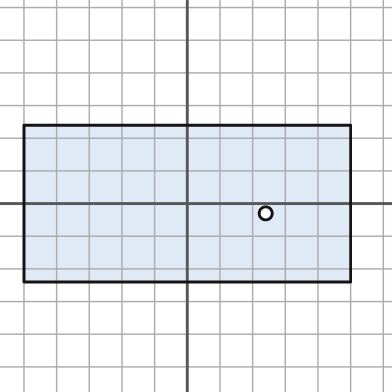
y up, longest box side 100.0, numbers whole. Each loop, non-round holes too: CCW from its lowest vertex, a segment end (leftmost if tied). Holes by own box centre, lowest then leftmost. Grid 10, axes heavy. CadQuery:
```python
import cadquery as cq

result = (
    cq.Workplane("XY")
    .moveTo(-50.0, -24.0)
    .lineTo(50.0, -24.0)
    .lineTo(50.0, 24.0)
    .lineTo(-50.0, 24.0)
    .close()
    .moveTo(24.0, -3.0)
    .circle(2.0)
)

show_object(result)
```